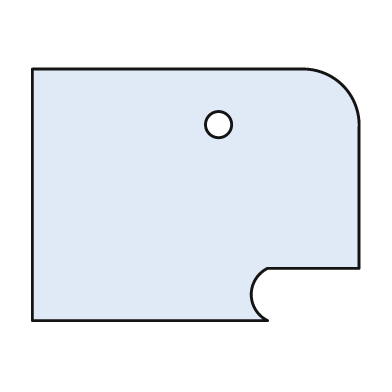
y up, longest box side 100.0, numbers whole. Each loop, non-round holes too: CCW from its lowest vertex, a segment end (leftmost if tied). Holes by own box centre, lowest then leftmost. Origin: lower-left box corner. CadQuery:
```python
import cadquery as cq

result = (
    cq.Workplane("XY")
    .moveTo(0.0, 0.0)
    .lineTo(72.0, 0.0)
    .threePointArc((67.0, 8.0), (72.0, 16.0))
    .lineTo(100.0, 16.0)
    .lineTo(100.0, 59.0)
    .threePointArc((95.0, 72.0), (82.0, 77.0))
    .lineTo(0.0, 77.0)
    .close()
    .moveTo(57.0, 60.0)
    .circle(4.0)
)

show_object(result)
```